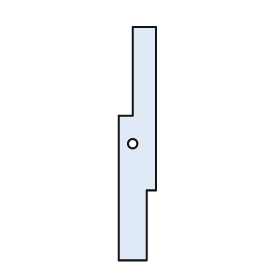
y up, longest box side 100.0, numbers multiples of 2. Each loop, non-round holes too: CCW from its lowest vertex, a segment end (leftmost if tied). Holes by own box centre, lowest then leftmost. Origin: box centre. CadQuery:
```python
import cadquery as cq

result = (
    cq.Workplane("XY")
    .moveTo(-8.0, -50.0)
    .lineTo(4.0, -50.0)
    .lineTo(4.0, -20.0)
    .lineTo(8.0, -20.0)
    .lineTo(8.0, 50.0)
    .lineTo(-2.0, 50.0)
    .lineTo(-2.0, 12.0)
    .lineTo(-8.0, 12.0)
    .close()
    .moveTo(-2.0, 0.0)
    .circle(2.0)
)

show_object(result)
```